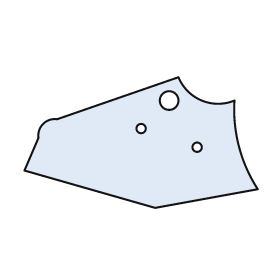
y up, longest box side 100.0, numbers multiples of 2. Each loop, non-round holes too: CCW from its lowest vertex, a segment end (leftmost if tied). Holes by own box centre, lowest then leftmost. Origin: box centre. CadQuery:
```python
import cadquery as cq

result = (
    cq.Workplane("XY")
    .moveTo(6.0, -28.0)
    .lineTo(50.0, -20.0)
    .threePointArc((42.0, -2.0), (40.0, 18.0))
    .threePointArc((26.0, 18.0), (16.0, 28.0))
    .lineTo(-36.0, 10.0)
    .threePointArc((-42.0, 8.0), (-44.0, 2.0))
    .lineTo(-50.0, -12.0)
    .close()
    .moveTo(24.0, -2.0)
    .circle(2.0)
    .moveTo(0.0, 6.0)
    .circle(2.0)
    .moveTo(12.0, 18.0)
    .circle(4.0)
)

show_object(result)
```